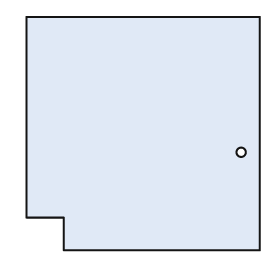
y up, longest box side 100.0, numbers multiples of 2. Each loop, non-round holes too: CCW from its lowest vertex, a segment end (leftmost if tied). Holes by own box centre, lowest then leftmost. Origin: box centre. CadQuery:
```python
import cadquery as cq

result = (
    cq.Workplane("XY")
    .moveTo(-34.0, -50.0)
    .lineTo(50.0, -50.0)
    .lineTo(50.0, 50.0)
    .lineTo(-50.0, 50.0)
    .lineTo(-50.0, -36.0)
    .lineTo(-34.0, -36.0)
    .close()
    .moveTo(42.0, -8.0)
    .circle(2.0)
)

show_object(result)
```